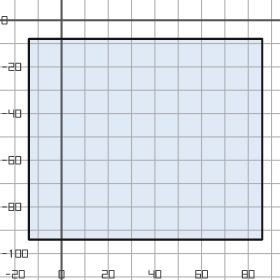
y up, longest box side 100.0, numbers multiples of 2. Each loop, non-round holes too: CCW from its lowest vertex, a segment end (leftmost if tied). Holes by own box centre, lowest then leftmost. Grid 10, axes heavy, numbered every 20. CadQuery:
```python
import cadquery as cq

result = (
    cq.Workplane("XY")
    .moveTo(-14.0, -94.0)
    .lineTo(86.0, -94.0)
    .lineTo(86.0, -8.0)
    .lineTo(-14.0, -8.0)
    .close()
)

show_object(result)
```